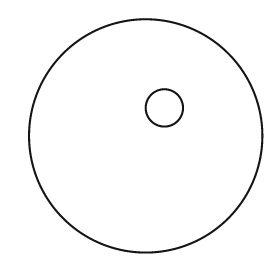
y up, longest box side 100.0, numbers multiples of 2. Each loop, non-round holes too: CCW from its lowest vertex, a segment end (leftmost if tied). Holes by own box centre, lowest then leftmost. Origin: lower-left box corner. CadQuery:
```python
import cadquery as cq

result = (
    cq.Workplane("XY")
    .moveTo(50.0, 50.0)
    .circle(50.0)
    .moveTo(58.0, 62.0)
    .circle(8.0)
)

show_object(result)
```